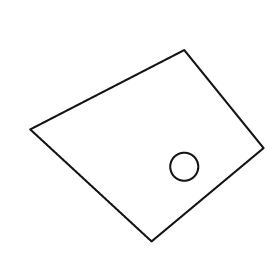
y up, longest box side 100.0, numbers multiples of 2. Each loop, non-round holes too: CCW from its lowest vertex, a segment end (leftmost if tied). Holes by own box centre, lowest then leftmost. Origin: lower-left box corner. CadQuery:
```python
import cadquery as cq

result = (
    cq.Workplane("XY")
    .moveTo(52.0, 0.0)
    .lineTo(100.0, 40.0)
    .lineTo(66.0, 82.0)
    .lineTo(0.0, 48.0)
    .close()
    .moveTo(66.0, 32.0)
    .circle(6.0)
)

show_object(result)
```